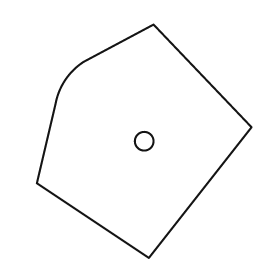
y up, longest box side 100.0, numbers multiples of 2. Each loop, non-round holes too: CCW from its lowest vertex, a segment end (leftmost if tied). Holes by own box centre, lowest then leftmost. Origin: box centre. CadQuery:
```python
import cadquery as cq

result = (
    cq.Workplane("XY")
    .moveTo(2.0, -50.0)
    .lineTo(46.0, 6.0)
    .lineTo(4.0, 50.0)
    .lineTo(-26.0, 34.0)
    .threePointArc((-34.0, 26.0), (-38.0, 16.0))
    .lineTo(-46.0, -18.0)
    .close()
    .moveTo(0.0, 0.0)
    .circle(4.0)
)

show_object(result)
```